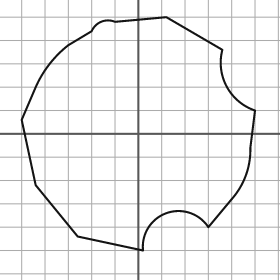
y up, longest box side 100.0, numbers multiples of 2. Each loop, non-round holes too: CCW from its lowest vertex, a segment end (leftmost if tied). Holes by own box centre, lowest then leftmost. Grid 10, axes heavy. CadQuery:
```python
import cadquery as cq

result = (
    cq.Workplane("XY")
    .moveTo(2.0, -50.0)
    .threePointArc((12.0, -34.0), (30.0, -40.0))
    .lineTo(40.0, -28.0)
    .threePointArc((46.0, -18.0), (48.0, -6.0))
    .lineTo(50.0, 10.0)
    .threePointArc((38.0, 20.0), (36.0, 36.0))
    .lineTo(12.0, 50.0)
    .lineTo(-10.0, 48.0)
    .threePointArc((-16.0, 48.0), (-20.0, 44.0))
    .lineTo(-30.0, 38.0)
    .threePointArc((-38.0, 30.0), (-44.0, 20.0))
    .lineTo(-50.0, 6.0)
    .lineTo(-44.0, -22.0)
    .lineTo(-26.0, -44.0)
    .close()
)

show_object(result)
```